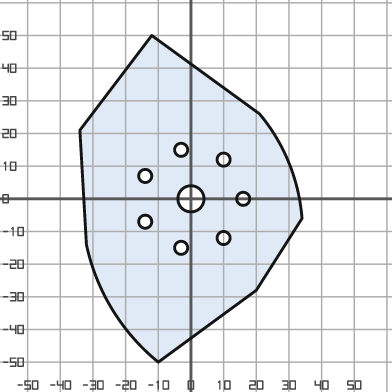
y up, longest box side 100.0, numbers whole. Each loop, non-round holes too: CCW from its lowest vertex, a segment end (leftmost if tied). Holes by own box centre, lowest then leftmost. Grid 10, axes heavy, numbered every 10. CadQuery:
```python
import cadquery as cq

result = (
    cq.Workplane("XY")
    .moveTo(-10.0, -50.0)
    .lineTo(20.0, -28.0)
    .lineTo(34.0, -6.0)
    .threePointArc((30.0, 11.0), (21.0, 26.0))
    .lineTo(-12.0, 50.0)
    .lineTo(-34.0, 21.0)
    .lineTo(-32.0, -14.0)
    .threePointArc((-24.0, -34.0), (-10.0, -50.0))
    .close()
    .moveTo(-3.0, -15.0)
    .circle(2.0)
    .moveTo(10.0, -12.0)
    .circle(2.0)
    .moveTo(-14.0, -7.0)
    .circle(2.0)
    .moveTo(0.0, 0.0)
    .circle(4.0)
    .moveTo(16.0, 0.0)
    .circle(2.0)
    .moveTo(-14.0, 7.0)
    .circle(2.0)
    .moveTo(10.0, 12.0)
    .circle(2.0)
    .moveTo(-3.0, 15.0)
    .circle(2.0)
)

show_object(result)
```